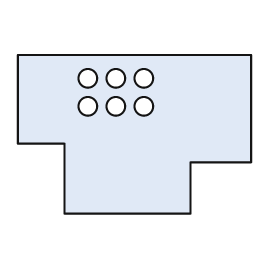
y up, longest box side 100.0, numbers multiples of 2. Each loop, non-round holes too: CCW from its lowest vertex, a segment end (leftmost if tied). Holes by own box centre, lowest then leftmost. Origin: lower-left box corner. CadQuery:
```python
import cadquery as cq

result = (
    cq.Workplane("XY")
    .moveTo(20.0, 0.0)
    .lineTo(74.0, 0.0)
    .lineTo(74.0, 22.0)
    .lineTo(100.0, 22.0)
    .lineTo(100.0, 68.0)
    .lineTo(0.0, 68.0)
    .lineTo(0.0, 30.0)
    .lineTo(20.0, 30.0)
    .close()
    .moveTo(30.0, 46.0)
    .circle(4.0)
    .moveTo(42.0, 46.0)
    .circle(4.0)
    .moveTo(54.0, 46.0)
    .circle(4.0)
    .moveTo(30.0, 58.0)
    .circle(4.0)
    .moveTo(42.0, 58.0)
    .circle(4.0)
    .moveTo(54.0, 58.0)
    .circle(4.0)
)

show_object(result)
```